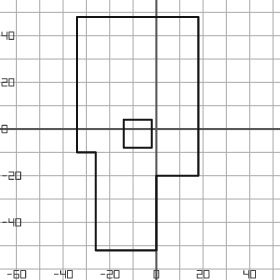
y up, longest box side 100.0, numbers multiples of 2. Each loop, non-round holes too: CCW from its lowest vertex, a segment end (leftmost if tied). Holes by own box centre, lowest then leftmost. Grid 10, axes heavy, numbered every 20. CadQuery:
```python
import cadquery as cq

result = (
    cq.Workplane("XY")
    .moveTo(-26.0, -52.0)
    .lineTo(0.0, -52.0)
    .lineTo(0.0, -20.0)
    .lineTo(18.0, -20.0)
    .lineTo(18.0, 48.0)
    .lineTo(-34.0, 48.0)
    .lineTo(-34.0, -10.0)
    .lineTo(-26.0, -10.0)
    .close()
    .moveTo(-14.0, -8.0)
    .lineTo(-2.0, -8.0)
    .lineTo(-2.0, 4.0)
    .lineTo(-14.0, 4.0)
    .close()
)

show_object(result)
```